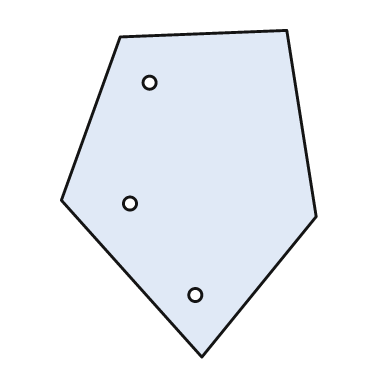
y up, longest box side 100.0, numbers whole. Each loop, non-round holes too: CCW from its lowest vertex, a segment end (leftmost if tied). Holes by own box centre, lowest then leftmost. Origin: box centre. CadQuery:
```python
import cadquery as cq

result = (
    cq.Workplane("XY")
    .moveTo(4.0, -50.0)
    .lineTo(39.0, -7.0)
    .lineTo(30.0, 50.0)
    .lineTo(-21.0, 48.0)
    .lineTo(-39.0, -2.0)
    .close()
    .moveTo(2.0, -31.0)
    .circle(2.0)
    .moveTo(-18.0, -3.0)
    .circle(2.0)
    .moveTo(-12.0, 34.0)
    .circle(2.0)
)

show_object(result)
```